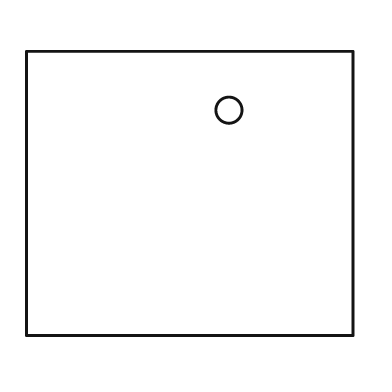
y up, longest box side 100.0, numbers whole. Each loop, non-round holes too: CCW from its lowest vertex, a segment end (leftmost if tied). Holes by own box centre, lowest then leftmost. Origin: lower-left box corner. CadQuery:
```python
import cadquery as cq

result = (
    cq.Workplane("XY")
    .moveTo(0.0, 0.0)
    .lineTo(100.0, 0.0)
    .lineTo(100.0, 87.0)
    .lineTo(0.0, 87.0)
    .close()
    .moveTo(62.0, 69.0)
    .circle(4.0)
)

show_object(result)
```